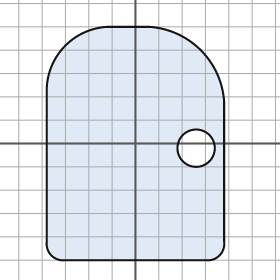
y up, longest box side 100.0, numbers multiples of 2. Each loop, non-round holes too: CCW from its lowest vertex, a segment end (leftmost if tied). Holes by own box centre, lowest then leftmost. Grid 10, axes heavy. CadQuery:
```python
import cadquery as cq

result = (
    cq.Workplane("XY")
    .moveTo(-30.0, -50.0)
    .lineTo(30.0, -50.0)
    .threePointArc((36.0, -48.0), (38.0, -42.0))
    .lineTo(38.0, 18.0)
    .threePointArc((28.0, 40.0), (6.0, 50.0))
    .lineTo(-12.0, 50.0)
    .threePointArc((-30.0, 42.0), (-38.0, 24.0))
    .lineTo(-38.0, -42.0)
    .threePointArc((-36.0, -48.0), (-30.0, -50.0))
    .close()
    .moveTo(26.0, -2.0)
    .circle(8.0)
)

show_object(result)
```